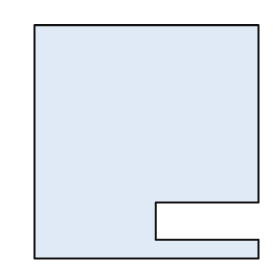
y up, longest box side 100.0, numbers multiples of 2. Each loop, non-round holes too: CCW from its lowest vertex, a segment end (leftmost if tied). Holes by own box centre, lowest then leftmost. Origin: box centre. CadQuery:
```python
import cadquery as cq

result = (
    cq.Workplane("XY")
    .moveTo(-48.0, -50.0)
    .lineTo(48.0, -50.0)
    .lineTo(48.0, -42.0)
    .lineTo(4.0, -42.0)
    .lineTo(4.0, -26.0)
    .lineTo(48.0, -26.0)
    .lineTo(48.0, 50.0)
    .lineTo(-48.0, 50.0)
    .close()
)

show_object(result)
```